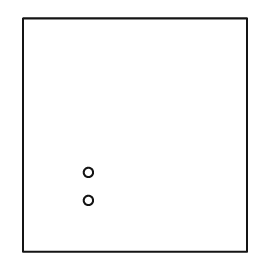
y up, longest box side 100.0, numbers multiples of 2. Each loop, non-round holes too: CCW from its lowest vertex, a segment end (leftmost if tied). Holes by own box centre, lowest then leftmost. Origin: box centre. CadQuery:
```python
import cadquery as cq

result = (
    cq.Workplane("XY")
    .moveTo(-48.0, -50.0)
    .lineTo(48.0, -50.0)
    .lineTo(48.0, 50.0)
    .lineTo(-48.0, 50.0)
    .close()
    .moveTo(-20.0, -28.0)
    .circle(2.0)
    .moveTo(-20.0, -16.0)
    .circle(2.0)
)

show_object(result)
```